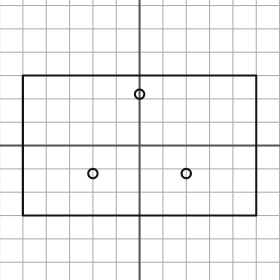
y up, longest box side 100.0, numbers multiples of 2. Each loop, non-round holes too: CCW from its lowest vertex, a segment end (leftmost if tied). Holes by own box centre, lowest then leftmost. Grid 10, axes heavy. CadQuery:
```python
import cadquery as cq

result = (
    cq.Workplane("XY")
    .moveTo(-50.0, -30.0)
    .lineTo(50.0, -30.0)
    .lineTo(50.0, 30.0)
    .lineTo(-50.0, 30.0)
    .close()
    .moveTo(-20.0, -12.0)
    .circle(2.0)
    .moveTo(20.0, -12.0)
    .circle(2.0)
    .moveTo(0.0, 22.0)
    .circle(2.0)
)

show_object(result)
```